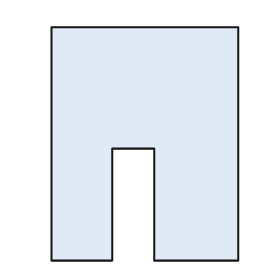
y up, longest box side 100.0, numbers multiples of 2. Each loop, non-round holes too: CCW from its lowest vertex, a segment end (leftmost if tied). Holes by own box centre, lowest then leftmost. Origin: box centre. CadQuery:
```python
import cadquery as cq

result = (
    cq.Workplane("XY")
    .moveTo(-40.0, -50.0)
    .lineTo(-14.0, -50.0)
    .lineTo(-14.0, -2.0)
    .lineTo(4.0, -2.0)
    .lineTo(4.0, -50.0)
    .lineTo(40.0, -50.0)
    .lineTo(40.0, 50.0)
    .lineTo(-40.0, 50.0)
    .close()
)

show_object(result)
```